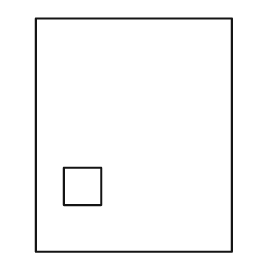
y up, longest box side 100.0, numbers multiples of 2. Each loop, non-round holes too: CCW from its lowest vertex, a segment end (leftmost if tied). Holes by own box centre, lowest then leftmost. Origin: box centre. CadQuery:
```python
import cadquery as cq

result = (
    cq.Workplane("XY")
    .moveTo(-42.0, -50.0)
    .lineTo(42.0, -50.0)
    .lineTo(42.0, 50.0)
    .lineTo(-42.0, 50.0)
    .close()
    .moveTo(-30.0, -30.0)
    .lineTo(-14.0, -30.0)
    .lineTo(-14.0, -14.0)
    .lineTo(-30.0, -14.0)
    .close()
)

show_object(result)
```